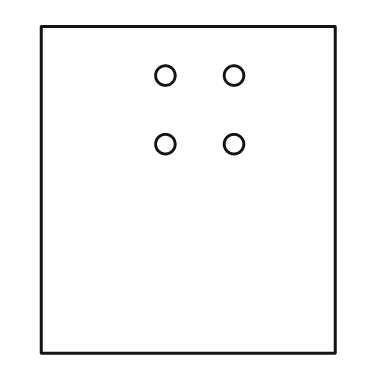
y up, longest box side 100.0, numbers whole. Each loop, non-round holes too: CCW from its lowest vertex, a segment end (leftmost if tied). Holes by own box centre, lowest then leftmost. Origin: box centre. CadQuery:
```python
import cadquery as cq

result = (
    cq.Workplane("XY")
    .moveTo(-45.0, -50.0)
    .lineTo(45.0, -50.0)
    .lineTo(45.0, 50.0)
    .lineTo(-45.0, 50.0)
    .close()
    .moveTo(-7.0, 14.0)
    .circle(3.0)
    .moveTo(14.0, 14.0)
    .circle(3.0)
    .moveTo(-7.0, 35.0)
    .circle(3.0)
    .moveTo(14.0, 35.0)
    .circle(3.0)
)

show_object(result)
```